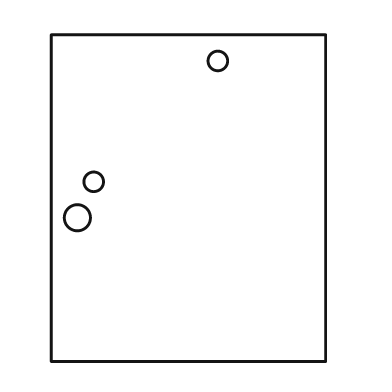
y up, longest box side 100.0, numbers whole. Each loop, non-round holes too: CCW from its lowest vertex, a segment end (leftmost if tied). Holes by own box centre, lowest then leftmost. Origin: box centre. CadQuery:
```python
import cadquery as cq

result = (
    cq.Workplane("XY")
    .moveTo(-42.0, -50.0)
    .lineTo(42.0, -50.0)
    .lineTo(42.0, 50.0)
    .lineTo(-42.0, 50.0)
    .close()
    .moveTo(-34.0, -6.0)
    .circle(4.0)
    .moveTo(-29.0, 5.0)
    .circle(3.0)
    .moveTo(9.0, 42.0)
    .circle(3.0)
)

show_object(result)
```